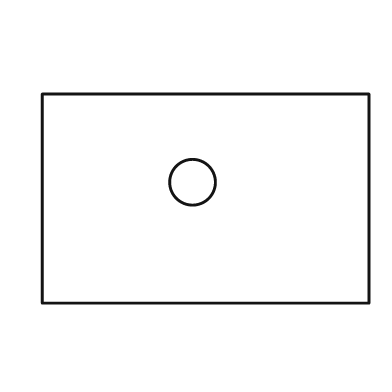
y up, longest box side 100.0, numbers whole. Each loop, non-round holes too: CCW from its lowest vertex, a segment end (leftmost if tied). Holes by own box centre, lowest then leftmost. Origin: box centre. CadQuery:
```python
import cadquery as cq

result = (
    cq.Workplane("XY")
    .moveTo(-50.0, -32.0)
    .lineTo(50.0, -32.0)
    .lineTo(50.0, 32.0)
    .lineTo(-50.0, 32.0)
    .close()
    .moveTo(-4.0, 5.0)
    .circle(7.0)
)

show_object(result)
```